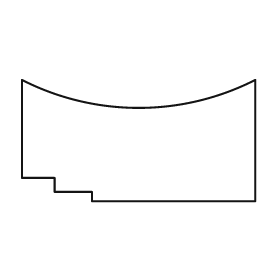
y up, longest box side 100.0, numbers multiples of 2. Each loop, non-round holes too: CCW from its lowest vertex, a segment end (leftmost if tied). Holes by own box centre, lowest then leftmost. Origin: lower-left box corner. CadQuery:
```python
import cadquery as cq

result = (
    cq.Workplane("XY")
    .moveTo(30.0, 0.0)
    .lineTo(100.0, 0.0)
    .lineTo(100.0, 52.0)
    .threePointArc((50.0, 40.0), (0.0, 52.0))
    .lineTo(0.0, 10.0)
    .lineTo(14.0, 10.0)
    .lineTo(14.0, 4.0)
    .lineTo(30.0, 4.0)
    .close()
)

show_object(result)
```